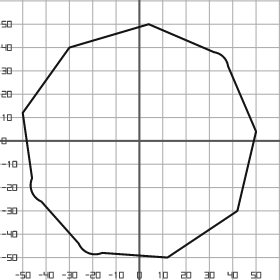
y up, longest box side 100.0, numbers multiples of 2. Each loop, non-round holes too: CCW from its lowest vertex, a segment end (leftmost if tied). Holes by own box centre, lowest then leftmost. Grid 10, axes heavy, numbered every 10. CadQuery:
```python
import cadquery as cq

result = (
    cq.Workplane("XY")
    .moveTo(12.0, -50.0)
    .lineTo(42.0, -30.0)
    .lineTo(50.0, 4.0)
    .lineTo(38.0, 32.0)
    .threePointArc((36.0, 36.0), (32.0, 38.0))
    .lineTo(4.0, 50.0)
    .lineTo(-30.0, 40.0)
    .lineTo(-50.0, 12.0)
    .lineTo(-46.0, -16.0)
    .threePointArc((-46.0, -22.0), (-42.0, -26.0))
    .lineTo(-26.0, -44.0)
    .threePointArc((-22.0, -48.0), (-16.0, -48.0))
    .close()
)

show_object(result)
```